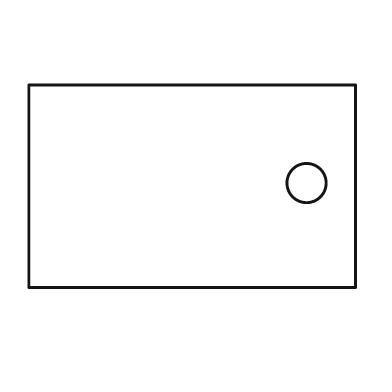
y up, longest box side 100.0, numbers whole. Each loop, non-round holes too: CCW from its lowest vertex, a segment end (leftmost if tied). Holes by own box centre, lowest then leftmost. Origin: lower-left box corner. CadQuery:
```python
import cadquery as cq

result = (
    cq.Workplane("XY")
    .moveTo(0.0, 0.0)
    .lineTo(100.0, 0.0)
    .lineTo(100.0, 62.0)
    .lineTo(0.0, 62.0)
    .close()
    .moveTo(85.0, 32.0)
    .circle(6.0)
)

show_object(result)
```